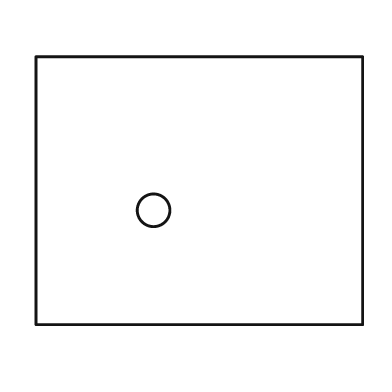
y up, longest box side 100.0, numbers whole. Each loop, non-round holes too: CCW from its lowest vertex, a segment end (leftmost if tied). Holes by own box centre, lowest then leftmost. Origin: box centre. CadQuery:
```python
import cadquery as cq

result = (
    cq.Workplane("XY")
    .moveTo(-50.0, -41.0)
    .lineTo(50.0, -41.0)
    .lineTo(50.0, 41.0)
    .lineTo(-50.0, 41.0)
    .close()
    .moveTo(-14.0, -6.0)
    .circle(5.0)
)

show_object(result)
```